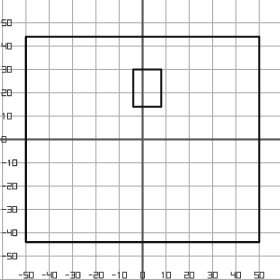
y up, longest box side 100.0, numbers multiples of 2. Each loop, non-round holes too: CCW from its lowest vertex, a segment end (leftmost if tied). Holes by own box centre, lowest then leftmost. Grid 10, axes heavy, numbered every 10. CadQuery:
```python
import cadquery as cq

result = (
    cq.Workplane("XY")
    .moveTo(-50.0, -44.0)
    .lineTo(50.0, -44.0)
    .lineTo(50.0, 44.0)
    .lineTo(-50.0, 44.0)
    .close()
    .moveTo(-4.0, 14.0)
    .lineTo(8.0, 14.0)
    .lineTo(8.0, 30.0)
    .lineTo(-4.0, 30.0)
    .close()
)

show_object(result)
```